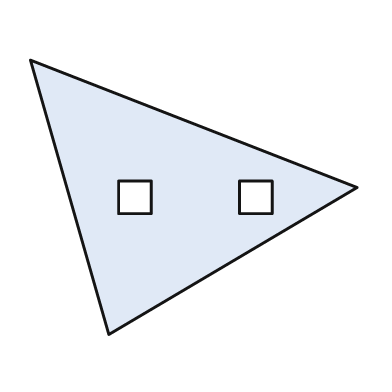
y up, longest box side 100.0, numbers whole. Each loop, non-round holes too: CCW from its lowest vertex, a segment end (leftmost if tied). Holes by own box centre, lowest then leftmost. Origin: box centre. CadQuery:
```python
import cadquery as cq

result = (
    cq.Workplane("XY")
    .moveTo(-26.0, -42.0)
    .lineTo(50.0, 3.0)
    .lineTo(-50.0, 42.0)
    .close()
    .moveTo(-23.0, -5.0)
    .lineTo(-13.0, -5.0)
    .lineTo(-13.0, 5.0)
    .lineTo(-23.0, 5.0)
    .close()
    .moveTo(14.0, -5.0)
    .lineTo(24.0, -5.0)
    .lineTo(24.0, 5.0)
    .lineTo(14.0, 5.0)
    .close()
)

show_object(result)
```